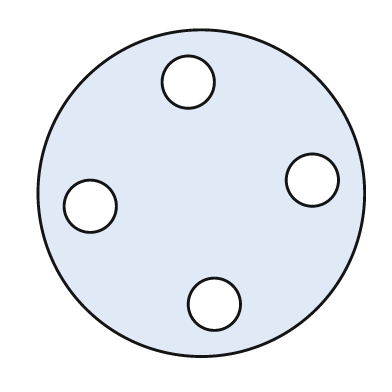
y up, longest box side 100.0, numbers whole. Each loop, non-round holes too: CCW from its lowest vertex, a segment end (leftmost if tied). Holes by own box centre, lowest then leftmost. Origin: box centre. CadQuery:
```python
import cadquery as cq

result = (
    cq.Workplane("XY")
    .moveTo(0.0, 0.0)
    .circle(50.0)
    .moveTo(4.0, -34.0)
    .circle(8.0)
    .moveTo(-34.0, -4.0)
    .circle(8.0)
    .moveTo(34.0, 4.0)
    .circle(8.0)
    .moveTo(-4.0, 34.0)
    .circle(8.0)
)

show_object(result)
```